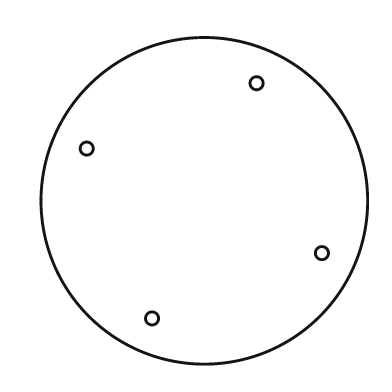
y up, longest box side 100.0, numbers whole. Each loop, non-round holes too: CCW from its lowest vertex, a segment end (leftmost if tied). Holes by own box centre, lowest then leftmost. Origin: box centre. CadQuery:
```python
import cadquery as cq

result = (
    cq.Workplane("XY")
    .moveTo(0.0, 0.0)
    .circle(50.0)
    .moveTo(-16.0, -36.0)
    .circle(2.0)
    .moveTo(36.0, -16.0)
    .circle(2.0)
    .moveTo(-36.0, 16.0)
    .circle(2.0)
    .moveTo(16.0, 36.0)
    .circle(2.0)
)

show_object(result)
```